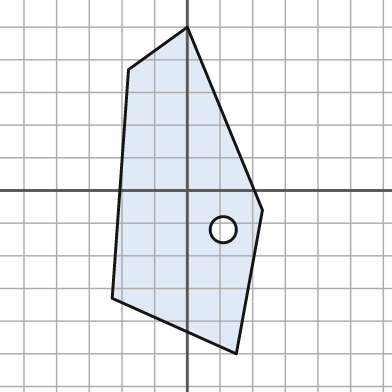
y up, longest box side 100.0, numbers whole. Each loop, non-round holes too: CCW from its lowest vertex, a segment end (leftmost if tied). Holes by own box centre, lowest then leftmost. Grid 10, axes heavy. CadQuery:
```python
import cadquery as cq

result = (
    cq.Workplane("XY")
    .moveTo(15.0, -50.0)
    .lineTo(23.0, -6.0)
    .lineTo(0.0, 50.0)
    .lineTo(-18.0, 37.0)
    .lineTo(-23.0, -33.0)
    .close()
    .moveTo(11.0, -12.0)
    .circle(4.0)
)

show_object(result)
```